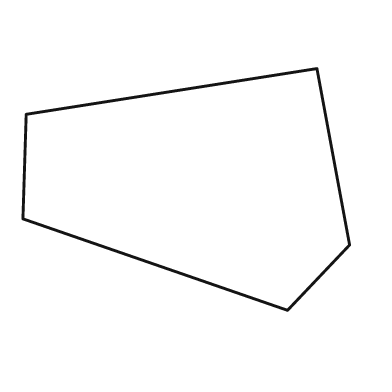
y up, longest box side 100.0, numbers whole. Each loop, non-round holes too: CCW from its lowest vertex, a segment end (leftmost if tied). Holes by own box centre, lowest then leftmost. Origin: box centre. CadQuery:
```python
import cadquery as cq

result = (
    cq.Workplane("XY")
    .moveTo(31.0, -37.0)
    .lineTo(50.0, -17.0)
    .lineTo(40.0, 37.0)
    .lineTo(-49.0, 23.0)
    .lineTo(-50.0, -9.0)
    .close()
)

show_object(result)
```